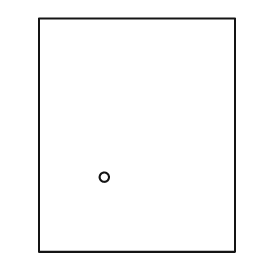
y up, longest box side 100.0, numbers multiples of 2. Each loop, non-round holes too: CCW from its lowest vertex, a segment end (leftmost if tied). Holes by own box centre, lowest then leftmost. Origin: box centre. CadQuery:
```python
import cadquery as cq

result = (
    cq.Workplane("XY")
    .moveTo(-42.0, -50.0)
    .lineTo(42.0, -50.0)
    .lineTo(42.0, 50.0)
    .lineTo(-42.0, 50.0)
    .close()
    .moveTo(-14.0, -18.0)
    .circle(2.0)
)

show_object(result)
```